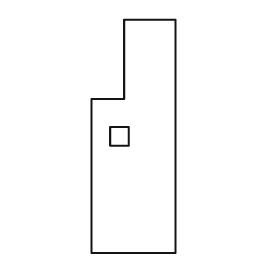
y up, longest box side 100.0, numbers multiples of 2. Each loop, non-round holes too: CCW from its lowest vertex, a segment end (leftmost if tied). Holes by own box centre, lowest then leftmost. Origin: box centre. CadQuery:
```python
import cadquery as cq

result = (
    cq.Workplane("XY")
    .moveTo(-18.0, -50.0)
    .lineTo(18.0, -50.0)
    .lineTo(18.0, 50.0)
    .lineTo(-4.0, 50.0)
    .lineTo(-4.0, 16.0)
    .lineTo(-18.0, 16.0)
    .close()
    .moveTo(-10.0, -4.0)
    .lineTo(-2.0, -4.0)
    .lineTo(-2.0, 4.0)
    .lineTo(-10.0, 4.0)
    .close()
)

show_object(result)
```